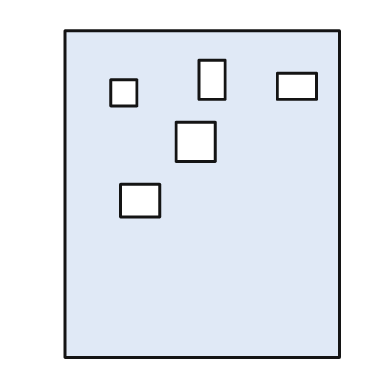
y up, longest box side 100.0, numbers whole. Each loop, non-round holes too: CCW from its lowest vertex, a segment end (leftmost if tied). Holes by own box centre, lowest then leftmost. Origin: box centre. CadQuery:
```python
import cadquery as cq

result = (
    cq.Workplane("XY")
    .moveTo(-42.0, -50.0)
    .lineTo(42.0, -50.0)
    .lineTo(42.0, 50.0)
    .lineTo(-42.0, 50.0)
    .close()
    .moveTo(-25.0, -7.0)
    .lineTo(-13.0, -7.0)
    .lineTo(-13.0, 3.0)
    .lineTo(-25.0, 3.0)
    .close()
    .moveTo(-8.0, 10.0)
    .lineTo(4.0, 10.0)
    .lineTo(4.0, 22.0)
    .lineTo(-8.0, 22.0)
    .close()
    .moveTo(-28.0, 27.0)
    .lineTo(-20.0, 27.0)
    .lineTo(-20.0, 35.0)
    .lineTo(-28.0, 35.0)
    .close()
    .moveTo(23.0, 29.0)
    .lineTo(35.0, 29.0)
    .lineTo(35.0, 37.0)
    .lineTo(23.0, 37.0)
    .close()
    .moveTo(-1.0, 29.0)
    .lineTo(7.0, 29.0)
    .lineTo(7.0, 41.0)
    .lineTo(-1.0, 41.0)
    .close()
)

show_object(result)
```